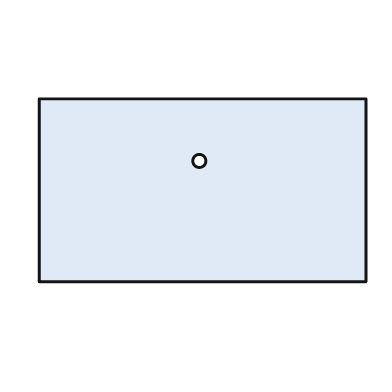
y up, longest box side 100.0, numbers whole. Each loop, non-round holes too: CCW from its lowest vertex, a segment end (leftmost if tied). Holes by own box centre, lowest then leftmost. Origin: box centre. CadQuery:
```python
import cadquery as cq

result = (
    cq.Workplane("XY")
    .moveTo(-50.0, -28.0)
    .lineTo(50.0, -28.0)
    .lineTo(50.0, 28.0)
    .lineTo(-50.0, 28.0)
    .close()
    .moveTo(-1.0, 9.0)
    .circle(2.0)
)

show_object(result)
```